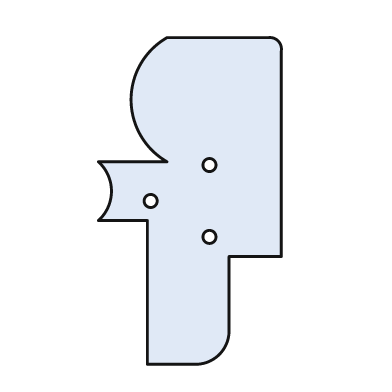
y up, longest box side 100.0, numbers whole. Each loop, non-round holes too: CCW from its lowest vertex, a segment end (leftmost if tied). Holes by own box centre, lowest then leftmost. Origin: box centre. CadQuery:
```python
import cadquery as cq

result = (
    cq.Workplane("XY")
    .moveTo(-13.0, -50.0)
    .lineTo(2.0, -50.0)
    .threePointArc((9.0, -47.0), (12.0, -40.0))
    .lineTo(12.0, -17.0)
    .lineTo(28.0, -17.0)
    .lineTo(28.0, 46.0)
    .threePointArc((27.0, 49.0), (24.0, 50.0))
    .lineTo(-7.0, 50.0)
    .threePointArc((-18.0, 31.0), (-7.0, 12.0))
    .lineTo(-28.0, 12.0)
    .threePointArc((-24.0, 3.0), (-28.0, -6.0))
    .lineTo(-13.0, -6.0)
    .close()
    .moveTo(6.0, -11.0)
    .circle(2.0)
    .moveTo(-12.0, 0.0)
    .circle(2.0)
    .moveTo(6.0, 11.0)
    .circle(2.0)
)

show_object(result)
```